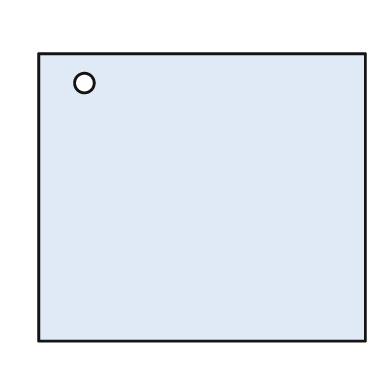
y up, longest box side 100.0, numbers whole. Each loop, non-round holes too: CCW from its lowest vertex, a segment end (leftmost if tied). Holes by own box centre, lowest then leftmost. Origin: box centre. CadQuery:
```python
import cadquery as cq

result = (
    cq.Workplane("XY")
    .moveTo(-50.0, -44.0)
    .lineTo(50.0, -44.0)
    .lineTo(50.0, 44.0)
    .lineTo(-50.0, 44.0)
    .close()
    .moveTo(-36.0, 35.0)
    .circle(3.0)
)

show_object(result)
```